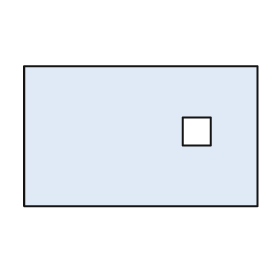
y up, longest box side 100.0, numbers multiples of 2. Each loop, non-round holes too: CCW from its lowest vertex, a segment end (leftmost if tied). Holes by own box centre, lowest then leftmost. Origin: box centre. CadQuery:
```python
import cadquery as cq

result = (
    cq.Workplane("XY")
    .moveTo(-50.0, -30.0)
    .lineTo(50.0, -30.0)
    .lineTo(50.0, 30.0)
    .lineTo(-50.0, 30.0)
    .close()
    .moveTo(18.0, -4.0)
    .lineTo(30.0, -4.0)
    .lineTo(30.0, 8.0)
    .lineTo(18.0, 8.0)
    .close()
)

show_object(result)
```